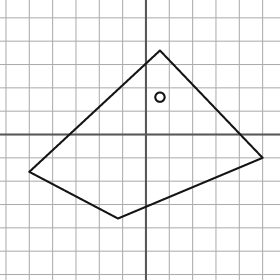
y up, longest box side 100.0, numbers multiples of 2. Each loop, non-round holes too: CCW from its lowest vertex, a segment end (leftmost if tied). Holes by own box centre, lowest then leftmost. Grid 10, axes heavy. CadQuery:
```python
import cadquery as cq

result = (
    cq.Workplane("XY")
    .moveTo(-12.0, -36.0)
    .lineTo(50.0, -10.0)
    .lineTo(6.0, 36.0)
    .lineTo(-50.0, -16.0)
    .close()
    .moveTo(6.0, 16.0)
    .circle(2.0)
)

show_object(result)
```